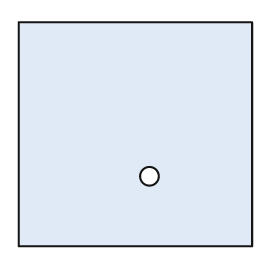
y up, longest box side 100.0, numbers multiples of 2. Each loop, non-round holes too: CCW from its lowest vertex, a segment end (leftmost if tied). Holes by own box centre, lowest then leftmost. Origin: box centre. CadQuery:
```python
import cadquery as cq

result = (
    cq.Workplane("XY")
    .moveTo(-50.0, -48.0)
    .lineTo(50.0, -48.0)
    .lineTo(50.0, 48.0)
    .lineTo(-50.0, 48.0)
    .close()
    .moveTo(6.0, -18.0)
    .circle(4.0)
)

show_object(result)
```